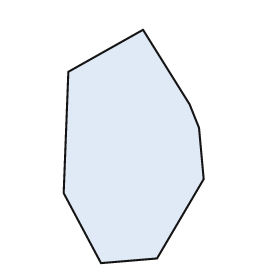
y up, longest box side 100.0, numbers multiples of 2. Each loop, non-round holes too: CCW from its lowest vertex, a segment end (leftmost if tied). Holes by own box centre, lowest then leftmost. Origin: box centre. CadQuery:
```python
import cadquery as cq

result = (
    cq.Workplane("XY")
    .moveTo(-14.0, -50.0)
    .lineTo(10.0, -48.0)
    .lineTo(30.0, -14.0)
    .lineTo(28.0, 8.0)
    .lineTo(24.0, 18.0)
    .lineTo(4.0, 50.0)
    .lineTo(-28.0, 32.0)
    .lineTo(-30.0, -20.0)
    .close()
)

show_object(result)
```